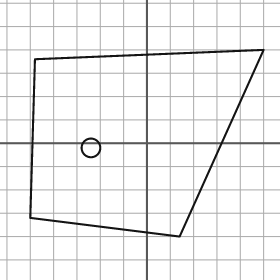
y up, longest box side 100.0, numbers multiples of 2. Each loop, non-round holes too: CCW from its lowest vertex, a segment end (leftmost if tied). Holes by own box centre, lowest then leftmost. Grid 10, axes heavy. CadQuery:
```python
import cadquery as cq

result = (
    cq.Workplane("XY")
    .moveTo(14.0, -40.0)
    .lineTo(50.0, 40.0)
    .lineTo(-48.0, 36.0)
    .lineTo(-50.0, -32.0)
    .close()
    .moveTo(-24.0, -2.0)
    .circle(4.0)
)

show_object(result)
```